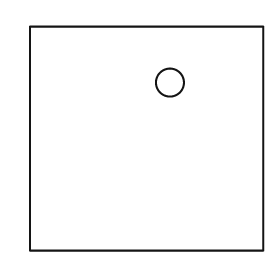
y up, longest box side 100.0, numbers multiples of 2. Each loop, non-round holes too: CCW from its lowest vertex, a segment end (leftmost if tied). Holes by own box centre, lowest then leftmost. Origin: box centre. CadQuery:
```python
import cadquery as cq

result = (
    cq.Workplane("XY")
    .moveTo(-50.0, -48.0)
    .lineTo(50.0, -48.0)
    .lineTo(50.0, 48.0)
    .lineTo(-50.0, 48.0)
    .close()
    .moveTo(10.0, 24.0)
    .circle(6.0)
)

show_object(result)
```